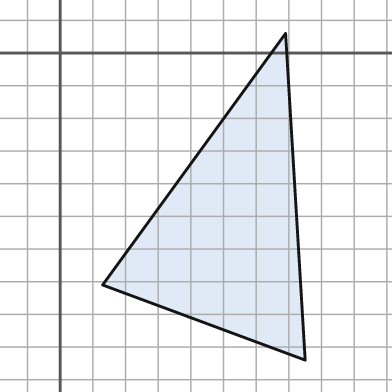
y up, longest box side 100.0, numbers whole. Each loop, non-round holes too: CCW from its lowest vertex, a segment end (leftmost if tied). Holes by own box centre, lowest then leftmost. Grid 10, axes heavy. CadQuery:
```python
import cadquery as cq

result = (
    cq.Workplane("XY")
    .moveTo(75.0, -94.0)
    .lineTo(69.0, 6.0)
    .lineTo(13.0, -71.0)
    .close()
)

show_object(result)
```